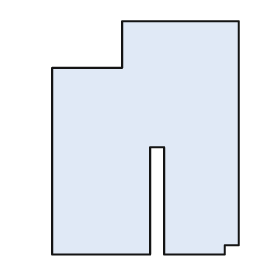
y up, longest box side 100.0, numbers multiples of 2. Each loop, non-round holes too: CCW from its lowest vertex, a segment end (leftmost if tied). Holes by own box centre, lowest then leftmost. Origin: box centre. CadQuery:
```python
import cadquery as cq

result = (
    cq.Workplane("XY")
    .moveTo(-40.0, -50.0)
    .lineTo(2.0, -50.0)
    .lineTo(2.0, -4.0)
    .lineTo(8.0, -4.0)
    .lineTo(8.0, -50.0)
    .lineTo(34.0, -50.0)
    .lineTo(34.0, -46.0)
    .lineTo(40.0, -46.0)
    .lineTo(40.0, 50.0)
    .lineTo(-10.0, 50.0)
    .lineTo(-10.0, 30.0)
    .lineTo(-40.0, 30.0)
    .close()
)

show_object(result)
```